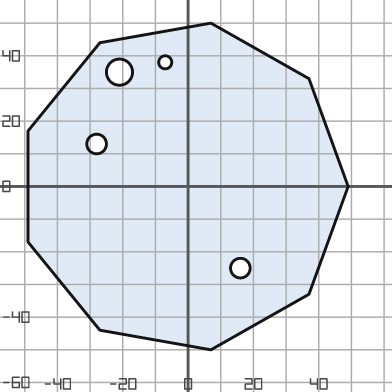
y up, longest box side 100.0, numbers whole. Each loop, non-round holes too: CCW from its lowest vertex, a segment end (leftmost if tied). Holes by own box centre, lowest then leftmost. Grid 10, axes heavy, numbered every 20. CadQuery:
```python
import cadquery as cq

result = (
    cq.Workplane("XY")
    .moveTo(7.0, -50.0)
    .lineTo(37.0, -33.0)
    .lineTo(49.0, 0.0)
    .lineTo(37.0, 33.0)
    .lineTo(7.0, 50.0)
    .lineTo(-27.0, 44.0)
    .lineTo(-49.0, 17.0)
    .lineTo(-49.0, -17.0)
    .lineTo(-27.0, -44.0)
    .close()
    .moveTo(16.0, -25.0)
    .circle(3.0)
    .moveTo(-28.0, 13.0)
    .circle(3.0)
    .moveTo(-21.0, 35.0)
    .circle(4.0)
    .moveTo(-7.0, 38.0)
    .circle(2.0)
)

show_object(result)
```